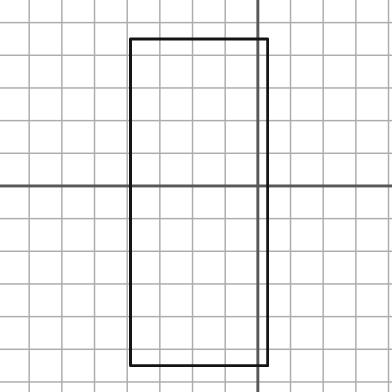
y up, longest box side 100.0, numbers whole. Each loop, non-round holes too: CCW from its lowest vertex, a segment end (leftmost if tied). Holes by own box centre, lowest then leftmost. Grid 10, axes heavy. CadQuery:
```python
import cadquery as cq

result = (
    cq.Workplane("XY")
    .moveTo(-39.0, -55.0)
    .lineTo(3.0, -55.0)
    .lineTo(3.0, 45.0)
    .lineTo(-39.0, 45.0)
    .close()
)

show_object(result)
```